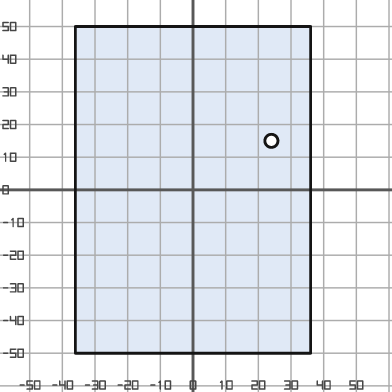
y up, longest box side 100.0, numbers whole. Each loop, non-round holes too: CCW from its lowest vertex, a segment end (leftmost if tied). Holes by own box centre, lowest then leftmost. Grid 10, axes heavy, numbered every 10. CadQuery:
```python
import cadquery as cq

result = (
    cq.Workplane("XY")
    .moveTo(-36.0, -50.0)
    .lineTo(36.0, -50.0)
    .lineTo(36.0, 50.0)
    .lineTo(-36.0, 50.0)
    .close()
    .moveTo(24.0, 15.0)
    .circle(2.0)
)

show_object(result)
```